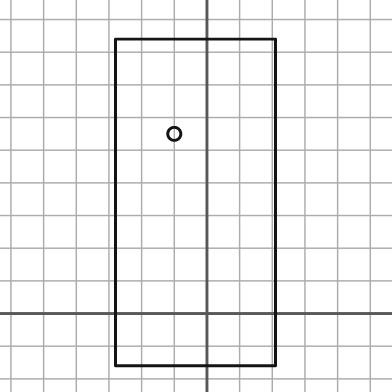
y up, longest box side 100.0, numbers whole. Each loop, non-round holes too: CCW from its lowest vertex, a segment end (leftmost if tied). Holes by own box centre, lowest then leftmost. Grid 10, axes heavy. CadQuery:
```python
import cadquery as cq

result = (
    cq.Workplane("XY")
    .moveTo(-28.0, -16.0)
    .lineTo(21.0, -16.0)
    .lineTo(21.0, 84.0)
    .lineTo(-28.0, 84.0)
    .close()
    .moveTo(-10.0, 55.0)
    .circle(2.0)
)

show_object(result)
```